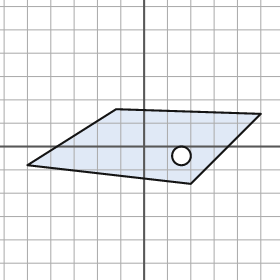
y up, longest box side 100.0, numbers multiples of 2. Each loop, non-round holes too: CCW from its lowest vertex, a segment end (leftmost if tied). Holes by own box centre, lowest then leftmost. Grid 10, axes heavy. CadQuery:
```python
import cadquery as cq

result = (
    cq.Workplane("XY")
    .moveTo(20.0, -16.0)
    .lineTo(50.0, 14.0)
    .lineTo(-12.0, 16.0)
    .lineTo(-50.0, -8.0)
    .close()
    .moveTo(16.0, -4.0)
    .circle(4.0)
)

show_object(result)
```